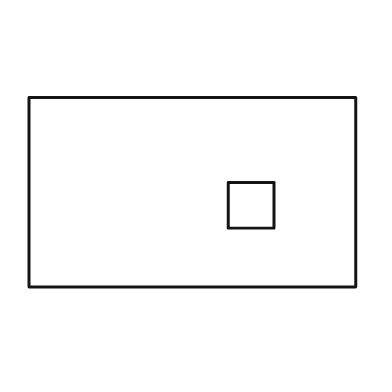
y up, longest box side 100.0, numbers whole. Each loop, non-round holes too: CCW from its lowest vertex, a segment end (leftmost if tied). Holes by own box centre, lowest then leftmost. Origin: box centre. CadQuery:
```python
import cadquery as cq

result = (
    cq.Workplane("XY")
    .moveTo(-50.0, -29.0)
    .lineTo(50.0, -29.0)
    .lineTo(50.0, 29.0)
    .lineTo(-50.0, 29.0)
    .close()
    .moveTo(11.0, -11.0)
    .lineTo(25.0, -11.0)
    .lineTo(25.0, 3.0)
    .lineTo(11.0, 3.0)
    .close()
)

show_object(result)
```